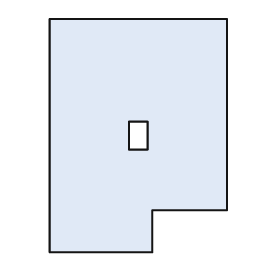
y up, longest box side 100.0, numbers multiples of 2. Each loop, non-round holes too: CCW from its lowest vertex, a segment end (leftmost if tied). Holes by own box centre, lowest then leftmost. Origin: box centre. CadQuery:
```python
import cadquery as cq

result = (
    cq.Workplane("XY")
    .moveTo(-38.0, -50.0)
    .lineTo(6.0, -50.0)
    .lineTo(6.0, -32.0)
    .lineTo(38.0, -32.0)
    .lineTo(38.0, 50.0)
    .lineTo(-38.0, 50.0)
    .close()
    .moveTo(-4.0, -6.0)
    .lineTo(4.0, -6.0)
    .lineTo(4.0, 6.0)
    .lineTo(-4.0, 6.0)
    .close()
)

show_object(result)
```